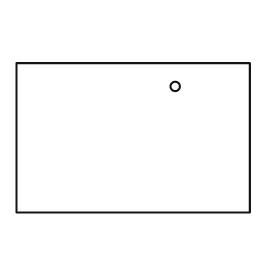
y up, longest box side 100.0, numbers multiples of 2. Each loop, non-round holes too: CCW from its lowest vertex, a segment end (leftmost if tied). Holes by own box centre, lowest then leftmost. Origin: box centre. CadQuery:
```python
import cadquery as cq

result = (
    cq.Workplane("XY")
    .moveTo(-50.0, -32.0)
    .lineTo(50.0, -32.0)
    .lineTo(50.0, 32.0)
    .lineTo(-50.0, 32.0)
    .close()
    .moveTo(18.0, 22.0)
    .circle(2.0)
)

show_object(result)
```